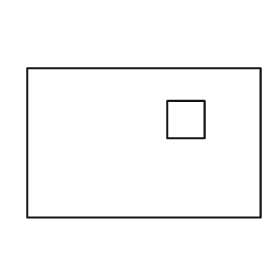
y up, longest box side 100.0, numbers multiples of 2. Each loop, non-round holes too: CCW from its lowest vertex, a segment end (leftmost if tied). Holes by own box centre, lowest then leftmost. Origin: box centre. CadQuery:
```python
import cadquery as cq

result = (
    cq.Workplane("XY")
    .moveTo(-50.0, -32.0)
    .lineTo(50.0, -32.0)
    .lineTo(50.0, 32.0)
    .lineTo(-50.0, 32.0)
    .close()
    .moveTo(10.0, 2.0)
    .lineTo(26.0, 2.0)
    .lineTo(26.0, 18.0)
    .lineTo(10.0, 18.0)
    .close()
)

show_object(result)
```